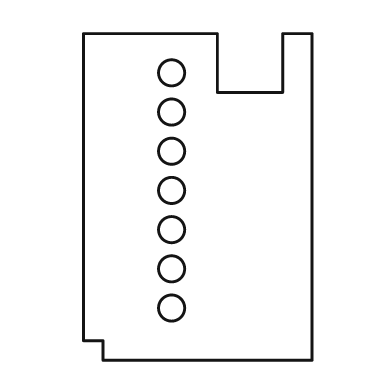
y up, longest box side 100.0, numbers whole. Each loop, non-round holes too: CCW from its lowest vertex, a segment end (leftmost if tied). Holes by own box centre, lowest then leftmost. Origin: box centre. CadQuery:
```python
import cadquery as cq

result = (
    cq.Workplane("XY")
    .moveTo(-29.0, -50.0)
    .lineTo(35.0, -50.0)
    .lineTo(35.0, 50.0)
    .lineTo(26.0, 50.0)
    .lineTo(26.0, 32.0)
    .lineTo(6.0, 32.0)
    .lineTo(6.0, 50.0)
    .lineTo(-35.0, 50.0)
    .lineTo(-35.0, -44.0)
    .lineTo(-29.0, -44.0)
    .close()
    .moveTo(-8.0, -34.0)
    .circle(4.0)
    .moveTo(-8.0, -22.0)
    .circle(4.0)
    .moveTo(-8.0, -10.0)
    .circle(4.0)
    .moveTo(-8.0, 2.0)
    .circle(4.0)
    .moveTo(-8.0, 14.0)
    .circle(4.0)
    .moveTo(-8.0, 26.0)
    .circle(4.0)
    .moveTo(-8.0, 38.0)
    .circle(4.0)
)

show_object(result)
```